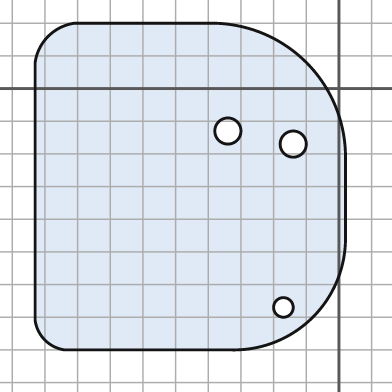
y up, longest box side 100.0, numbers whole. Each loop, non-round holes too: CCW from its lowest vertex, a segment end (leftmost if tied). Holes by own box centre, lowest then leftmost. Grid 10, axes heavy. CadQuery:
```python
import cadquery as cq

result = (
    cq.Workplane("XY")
    .moveTo(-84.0, -80.0)
    .lineTo(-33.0, -80.0)
    .threePointArc((-8.0, -70.0), (2.0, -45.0))
    .lineTo(2.0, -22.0)
    .threePointArc((-10.0, 8.0), (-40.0, 20.0))
    .lineTo(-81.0, 20.0)
    .threePointArc((-89.0, 16.0), (-93.0, 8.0))
    .lineTo(-93.0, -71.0)
    .threePointArc((-90.0, -77.0), (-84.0, -80.0))
    .close()
    .moveTo(-17.0, -67.0)
    .circle(3.0)
    .moveTo(-14.0, -17.0)
    .circle(4.0)
    .moveTo(-34.0, -13.0)
    .circle(4.0)
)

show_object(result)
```